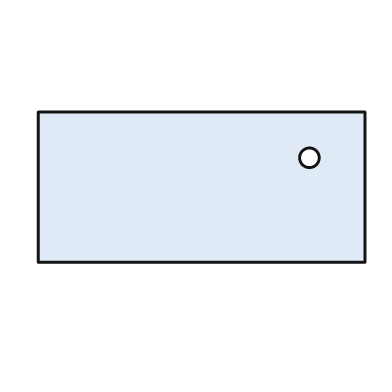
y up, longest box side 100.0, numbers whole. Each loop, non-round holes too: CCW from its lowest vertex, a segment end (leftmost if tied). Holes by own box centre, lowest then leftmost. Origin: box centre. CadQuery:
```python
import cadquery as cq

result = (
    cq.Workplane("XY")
    .moveTo(-50.0, -23.0)
    .lineTo(50.0, -23.0)
    .lineTo(50.0, 23.0)
    .lineTo(-50.0, 23.0)
    .close()
    .moveTo(33.0, 9.0)
    .circle(3.0)
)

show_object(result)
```